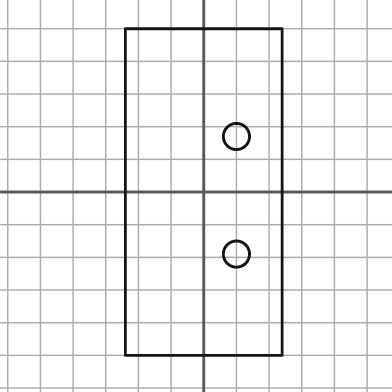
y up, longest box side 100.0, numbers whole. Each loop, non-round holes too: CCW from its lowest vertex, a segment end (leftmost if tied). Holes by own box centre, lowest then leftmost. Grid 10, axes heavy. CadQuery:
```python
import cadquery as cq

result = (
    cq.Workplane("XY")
    .moveTo(-24.0, -50.0)
    .lineTo(24.0, -50.0)
    .lineTo(24.0, 50.0)
    .lineTo(-24.0, 50.0)
    .close()
    .moveTo(10.0, -19.0)
    .circle(4.0)
    .moveTo(10.0, 17.0)
    .circle(4.0)
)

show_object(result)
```